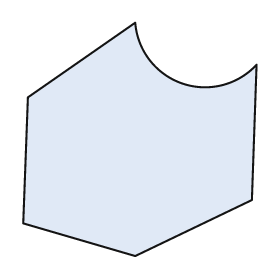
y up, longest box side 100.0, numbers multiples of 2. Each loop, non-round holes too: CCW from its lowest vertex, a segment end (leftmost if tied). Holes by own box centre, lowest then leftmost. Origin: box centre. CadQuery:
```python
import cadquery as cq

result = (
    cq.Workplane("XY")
    .moveTo(-2.0, -50.0)
    .lineTo(48.0, -26.0)
    .lineTo(50.0, 32.0)
    .threePointArc((18.0, 24.0), (-2.0, 50.0))
    .lineTo(-48.0, 18.0)
    .lineTo(-50.0, -36.0)
    .close()
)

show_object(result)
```